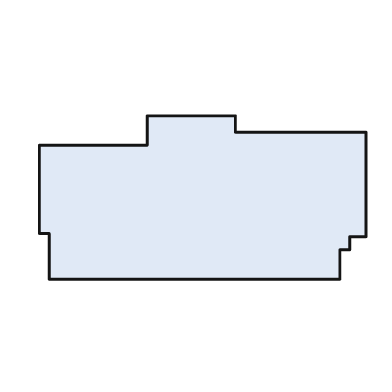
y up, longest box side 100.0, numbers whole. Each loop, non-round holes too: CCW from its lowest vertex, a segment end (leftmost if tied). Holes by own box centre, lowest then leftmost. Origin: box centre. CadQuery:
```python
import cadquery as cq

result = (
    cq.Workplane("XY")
    .moveTo(-47.0, -25.0)
    .lineTo(42.0, -25.0)
    .lineTo(42.0, -16.0)
    .lineTo(45.0, -16.0)
    .lineTo(45.0, -12.0)
    .lineTo(50.0, -12.0)
    .lineTo(50.0, 20.0)
    .lineTo(10.0, 20.0)
    .lineTo(10.0, 25.0)
    .lineTo(-17.0, 25.0)
    .lineTo(-17.0, 16.0)
    .lineTo(-50.0, 16.0)
    .lineTo(-50.0, -11.0)
    .lineTo(-47.0, -11.0)
    .close()
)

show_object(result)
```